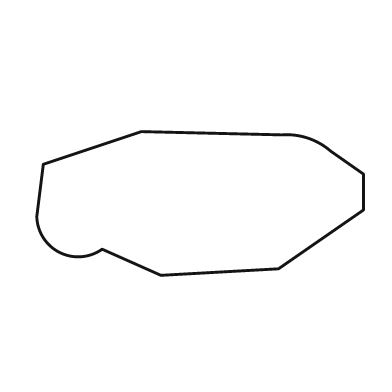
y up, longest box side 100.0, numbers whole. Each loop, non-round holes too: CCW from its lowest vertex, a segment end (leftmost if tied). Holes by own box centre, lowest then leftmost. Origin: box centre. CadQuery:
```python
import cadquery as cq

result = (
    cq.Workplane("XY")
    .moveTo(-12.0, -22.0)
    .lineTo(24.0, -20.0)
    .lineTo(50.0, -2.0)
    .lineTo(50.0, 9.0)
    .lineTo(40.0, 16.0)
    .threePointArc((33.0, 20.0), (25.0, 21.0))
    .lineTo(-18.0, 22.0)
    .lineTo(-48.0, 12.0)
    .lineTo(-50.0, -4.0)
    .threePointArc((-43.0, -15.0), (-30.0, -14.0))
    .close()
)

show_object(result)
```